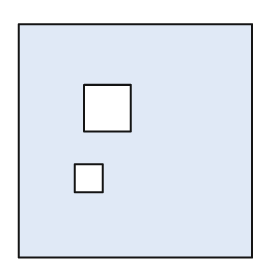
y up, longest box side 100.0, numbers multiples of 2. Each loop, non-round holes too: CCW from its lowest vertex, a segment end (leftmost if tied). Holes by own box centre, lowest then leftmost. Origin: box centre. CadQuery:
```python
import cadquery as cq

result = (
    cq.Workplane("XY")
    .moveTo(-50.0, -50.0)
    .lineTo(50.0, -50.0)
    .lineTo(50.0, 50.0)
    .lineTo(-50.0, 50.0)
    .close()
    .moveTo(-26.0, -22.0)
    .lineTo(-14.0, -22.0)
    .lineTo(-14.0, -10.0)
    .lineTo(-26.0, -10.0)
    .close()
    .moveTo(-22.0, 4.0)
    .lineTo(-2.0, 4.0)
    .lineTo(-2.0, 24.0)
    .lineTo(-22.0, 24.0)
    .close()
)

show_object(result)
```